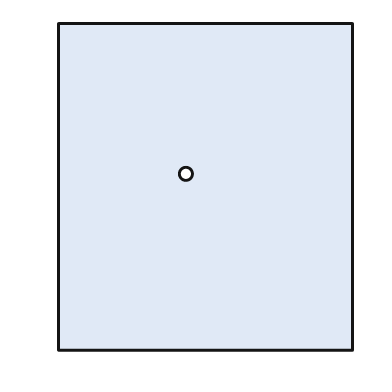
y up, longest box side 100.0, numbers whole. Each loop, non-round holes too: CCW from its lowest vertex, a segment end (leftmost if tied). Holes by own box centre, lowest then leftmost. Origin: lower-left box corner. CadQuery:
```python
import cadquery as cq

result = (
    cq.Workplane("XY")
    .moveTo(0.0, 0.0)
    .lineTo(90.0, 0.0)
    .lineTo(90.0, 100.0)
    .lineTo(0.0, 100.0)
    .close()
    .moveTo(39.0, 54.0)
    .circle(2.0)
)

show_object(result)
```